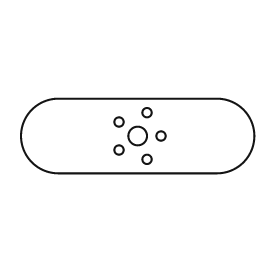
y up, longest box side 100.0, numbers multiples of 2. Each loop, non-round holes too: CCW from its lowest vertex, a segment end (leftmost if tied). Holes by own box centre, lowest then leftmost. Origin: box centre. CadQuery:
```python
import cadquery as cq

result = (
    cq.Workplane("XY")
    .moveTo(-34.0, -16.0)
    .lineTo(34.0, -16.0)
    .threePointArc((50.0, 0.0), (34.0, 16.0))
    .lineTo(-34.0, 16.0)
    .threePointArc((-50.0, 0.0), (-34.0, -16.0))
    .close()
    .moveTo(4.0, -10.0)
    .circle(2.0)
    .moveTo(-8.0, -6.0)
    .circle(2.0)
    .moveTo(0.0, 0.0)
    .circle(4.0)
    .moveTo(10.0, 0.0)
    .circle(2.0)
    .moveTo(-8.0, 6.0)
    .circle(2.0)
    .moveTo(4.0, 10.0)
    .circle(2.0)
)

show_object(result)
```